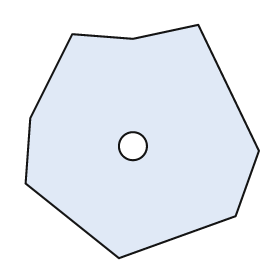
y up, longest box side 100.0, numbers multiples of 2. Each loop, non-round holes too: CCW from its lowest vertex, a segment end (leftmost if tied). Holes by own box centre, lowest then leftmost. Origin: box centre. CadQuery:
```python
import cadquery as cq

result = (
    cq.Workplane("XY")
    .moveTo(-10.0, -50.0)
    .lineTo(40.0, -32.0)
    .lineTo(50.0, -4.0)
    .lineTo(24.0, 50.0)
    .lineTo(-4.0, 44.0)
    .lineTo(-30.0, 46.0)
    .lineTo(-48.0, 10.0)
    .lineTo(-50.0, -18.0)
    .close()
    .moveTo(-4.0, -2.0)
    .circle(6.0)
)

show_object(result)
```